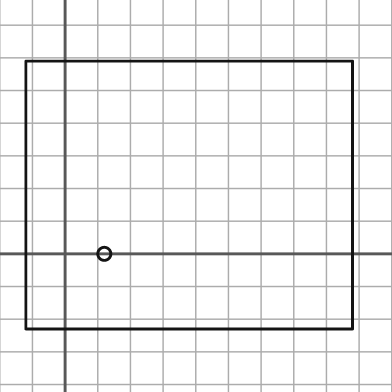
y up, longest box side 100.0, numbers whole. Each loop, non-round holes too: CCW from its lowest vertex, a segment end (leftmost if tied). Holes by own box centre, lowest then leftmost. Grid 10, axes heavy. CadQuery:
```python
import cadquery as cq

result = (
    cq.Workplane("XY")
    .moveTo(-12.0, -23.0)
    .lineTo(88.0, -23.0)
    .lineTo(88.0, 59.0)
    .lineTo(-12.0, 59.0)
    .close()
    .moveTo(12.0, 0.0)
    .circle(2.0)
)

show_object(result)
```